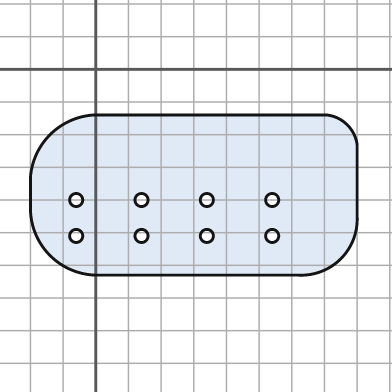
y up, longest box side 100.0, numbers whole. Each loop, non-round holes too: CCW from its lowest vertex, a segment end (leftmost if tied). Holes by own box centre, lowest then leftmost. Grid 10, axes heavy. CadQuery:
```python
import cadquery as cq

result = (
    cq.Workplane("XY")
    .moveTo(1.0, -63.0)
    .lineTo(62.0, -63.0)
    .threePointArc((75.0, -58.0), (80.0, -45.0))
    .lineTo(80.0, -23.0)
    .threePointArc((77.0, -17.0), (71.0, -14.0))
    .lineTo(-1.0, -14.0)
    .threePointArc((-14.0, -20.0), (-20.0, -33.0))
    .lineTo(-20.0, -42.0)
    .threePointArc((-14.0, -57.0), (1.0, -63.0))
    .close()
    .moveTo(-6.0, -51.0)
    .circle(2.0)
    .moveTo(14.0, -51.0)
    .circle(2.0)
    .moveTo(34.0, -51.0)
    .circle(2.0)
    .moveTo(54.0, -51.0)
    .circle(2.0)
    .moveTo(-6.0, -40.0)
    .circle(2.0)
    .moveTo(14.0, -40.0)
    .circle(2.0)
    .moveTo(34.0, -40.0)
    .circle(2.0)
    .moveTo(54.0, -40.0)
    .circle(2.0)
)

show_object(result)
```